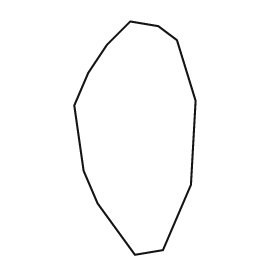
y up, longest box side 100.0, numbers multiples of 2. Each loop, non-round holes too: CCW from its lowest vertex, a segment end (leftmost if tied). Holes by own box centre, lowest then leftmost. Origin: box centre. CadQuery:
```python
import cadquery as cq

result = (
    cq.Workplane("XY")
    .moveTo(0.0, -50.0)
    .lineTo(12.0, -48.0)
    .lineTo(24.0, -20.0)
    .lineTo(26.0, 16.0)
    .lineTo(18.0, 42.0)
    .lineTo(10.0, 48.0)
    .lineTo(-2.0, 50.0)
    .lineTo(-12.0, 40.0)
    .lineTo(-20.0, 28.0)
    .lineTo(-26.0, 14.0)
    .lineTo(-22.0, -14.0)
    .lineTo(-16.0, -28.0)
    .close()
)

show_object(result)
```